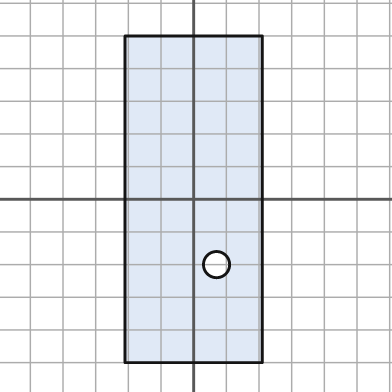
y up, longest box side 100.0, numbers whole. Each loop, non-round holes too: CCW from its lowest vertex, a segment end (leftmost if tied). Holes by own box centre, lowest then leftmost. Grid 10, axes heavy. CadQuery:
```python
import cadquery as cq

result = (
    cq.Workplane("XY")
    .moveTo(-21.0, -50.0)
    .lineTo(21.0, -50.0)
    .lineTo(21.0, 50.0)
    .lineTo(-21.0, 50.0)
    .close()
    .moveTo(7.0, -20.0)
    .circle(4.0)
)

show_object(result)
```